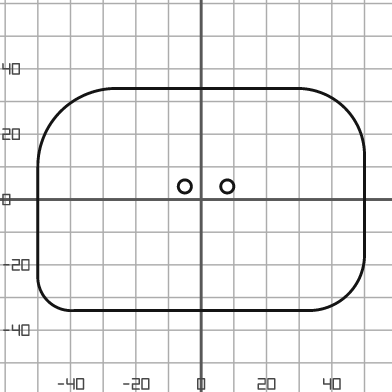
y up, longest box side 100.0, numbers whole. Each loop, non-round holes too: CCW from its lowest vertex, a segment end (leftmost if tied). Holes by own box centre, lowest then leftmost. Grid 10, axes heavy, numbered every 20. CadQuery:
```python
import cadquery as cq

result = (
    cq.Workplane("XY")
    .moveTo(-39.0, -34.0)
    .lineTo(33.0, -34.0)
    .threePointArc((45.0, -29.0), (50.0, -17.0))
    .lineTo(50.0, 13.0)
    .threePointArc((44.0, 28.0), (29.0, 34.0))
    .lineTo(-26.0, 34.0)
    .threePointArc((-43.0, 27.0), (-50.0, 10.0))
    .lineTo(-50.0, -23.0)
    .threePointArc((-47.0, -31.0), (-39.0, -34.0))
    .close()
    .moveTo(-5.0, 4.0)
    .circle(2.0)
    .moveTo(8.0, 4.0)
    .circle(2.0)
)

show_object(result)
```